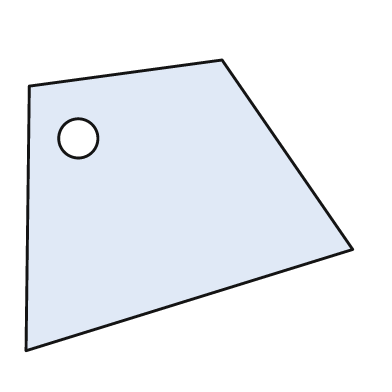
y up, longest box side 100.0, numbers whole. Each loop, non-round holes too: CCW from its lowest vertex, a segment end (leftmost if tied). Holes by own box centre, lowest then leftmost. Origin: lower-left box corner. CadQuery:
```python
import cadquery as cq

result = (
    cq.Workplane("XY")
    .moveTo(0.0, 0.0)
    .lineTo(100.0, 31.0)
    .lineTo(60.0, 89.0)
    .lineTo(1.0, 81.0)
    .close()
    .moveTo(16.0, 65.0)
    .circle(6.0)
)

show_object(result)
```